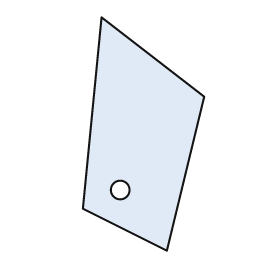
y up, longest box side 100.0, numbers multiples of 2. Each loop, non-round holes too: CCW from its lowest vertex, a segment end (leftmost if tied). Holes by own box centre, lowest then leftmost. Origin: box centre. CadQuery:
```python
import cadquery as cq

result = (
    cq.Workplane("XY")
    .moveTo(10.0, -50.0)
    .lineTo(26.0, 16.0)
    .lineTo(-18.0, 50.0)
    .lineTo(-26.0, -32.0)
    .close()
    .moveTo(-10.0, -24.0)
    .circle(4.0)
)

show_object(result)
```